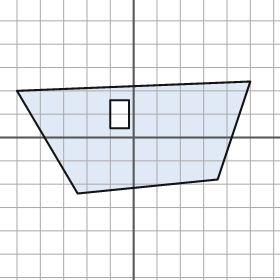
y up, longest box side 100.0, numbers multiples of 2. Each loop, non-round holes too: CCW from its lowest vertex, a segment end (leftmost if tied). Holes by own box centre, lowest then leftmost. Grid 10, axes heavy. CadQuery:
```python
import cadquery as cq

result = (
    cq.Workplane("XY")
    .moveTo(-24.0, -24.0)
    .lineTo(36.0, -18.0)
    .lineTo(50.0, 24.0)
    .lineTo(-50.0, 20.0)
    .close()
    .moveTo(-10.0, 4.0)
    .lineTo(-2.0, 4.0)
    .lineTo(-2.0, 16.0)
    .lineTo(-10.0, 16.0)
    .close()
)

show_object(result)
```